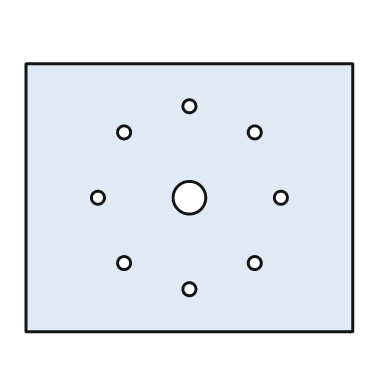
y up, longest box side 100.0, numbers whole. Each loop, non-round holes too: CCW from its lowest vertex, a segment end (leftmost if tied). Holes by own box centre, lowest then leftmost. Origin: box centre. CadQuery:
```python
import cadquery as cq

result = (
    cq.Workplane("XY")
    .moveTo(-50.0, -41.0)
    .lineTo(50.0, -41.0)
    .lineTo(50.0, 41.0)
    .lineTo(-50.0, 41.0)
    .close()
    .moveTo(0.0, -28.0)
    .circle(2.0)
    .moveTo(-20.0, -20.0)
    .circle(2.0)
    .moveTo(20.0, -20.0)
    .circle(2.0)
    .moveTo(-28.0, 0.0)
    .circle(2.0)
    .moveTo(0.0, 0.0)
    .circle(5.0)
    .moveTo(28.0, 0.0)
    .circle(2.0)
    .moveTo(-20.0, 20.0)
    .circle(2.0)
    .moveTo(20.0, 20.0)
    .circle(2.0)
    .moveTo(0.0, 28.0)
    .circle(2.0)
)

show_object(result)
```